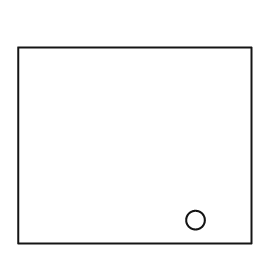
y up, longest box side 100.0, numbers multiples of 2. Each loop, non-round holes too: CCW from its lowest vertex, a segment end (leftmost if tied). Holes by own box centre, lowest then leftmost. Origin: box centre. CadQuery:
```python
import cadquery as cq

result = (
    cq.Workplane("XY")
    .moveTo(-50.0, -42.0)
    .lineTo(50.0, -42.0)
    .lineTo(50.0, 42.0)
    .lineTo(-50.0, 42.0)
    .close()
    .moveTo(26.0, -32.0)
    .circle(4.0)
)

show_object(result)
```